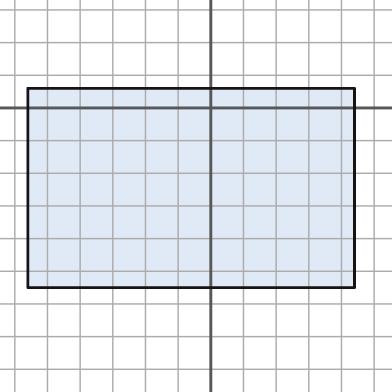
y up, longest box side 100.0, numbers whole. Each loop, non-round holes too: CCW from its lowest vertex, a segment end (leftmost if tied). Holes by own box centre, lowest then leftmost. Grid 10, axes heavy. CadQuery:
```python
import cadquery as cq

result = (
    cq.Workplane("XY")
    .moveTo(-56.0, -55.0)
    .lineTo(44.0, -55.0)
    .lineTo(44.0, 6.0)
    .lineTo(-56.0, 6.0)
    .close()
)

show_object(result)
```